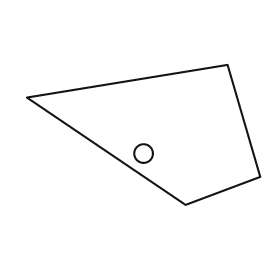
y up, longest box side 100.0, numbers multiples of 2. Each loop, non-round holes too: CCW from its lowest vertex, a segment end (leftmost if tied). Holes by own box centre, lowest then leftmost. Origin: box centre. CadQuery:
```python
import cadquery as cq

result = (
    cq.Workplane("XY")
    .moveTo(18.0, -30.0)
    .lineTo(50.0, -18.0)
    .lineTo(36.0, 30.0)
    .lineTo(-50.0, 16.0)
    .close()
    .moveTo(0.0, -8.0)
    .circle(4.0)
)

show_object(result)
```